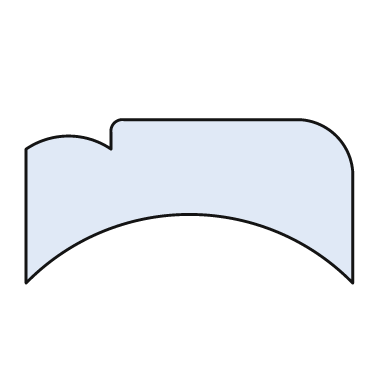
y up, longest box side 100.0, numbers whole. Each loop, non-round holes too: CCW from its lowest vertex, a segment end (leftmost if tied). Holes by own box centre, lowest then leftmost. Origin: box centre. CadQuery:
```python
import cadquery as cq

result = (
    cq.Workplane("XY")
    .moveTo(-50.0, -25.0)
    .threePointArc((0.0, -4.0), (50.0, -25.0))
    .lineTo(50.0, 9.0)
    .threePointArc((45.0, 20.0), (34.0, 25.0))
    .lineTo(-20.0, 25.0)
    .threePointArc((-23.0, 24.0), (-24.0, 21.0))
    .lineTo(-24.0, 16.0)
    .threePointArc((-37.0, 20.0), (-50.0, 16.0))
    .close()
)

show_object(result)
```